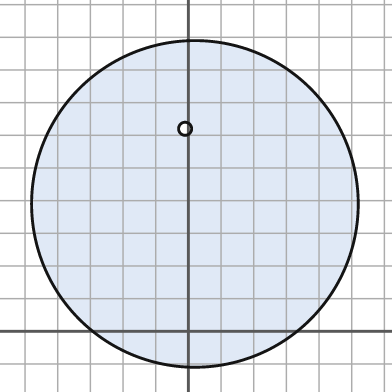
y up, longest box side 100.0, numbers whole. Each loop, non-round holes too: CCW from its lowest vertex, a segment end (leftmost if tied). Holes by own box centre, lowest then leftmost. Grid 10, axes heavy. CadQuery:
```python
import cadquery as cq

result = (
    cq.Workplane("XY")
    .moveTo(2.0, 39.0)
    .circle(50.0)
    .moveTo(-1.0, 62.0)
    .circle(2.0)
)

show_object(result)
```